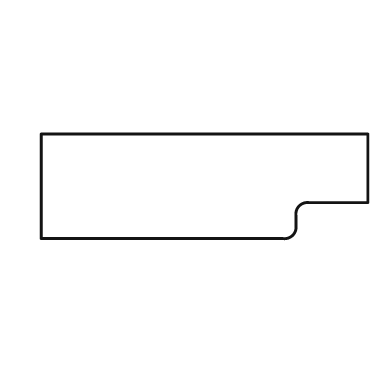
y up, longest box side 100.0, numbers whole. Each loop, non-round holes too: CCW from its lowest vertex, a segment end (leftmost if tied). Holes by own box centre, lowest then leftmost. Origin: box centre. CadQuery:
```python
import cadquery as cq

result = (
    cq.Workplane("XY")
    .moveTo(-50.0, -16.0)
    .lineTo(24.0, -16.0)
    .threePointArc((27.0, -15.0), (28.0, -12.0))
    .lineTo(28.0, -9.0)
    .threePointArc((29.0, -6.0), (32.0, -5.0))
    .lineTo(50.0, -5.0)
    .lineTo(50.0, 16.0)
    .lineTo(-50.0, 16.0)
    .close()
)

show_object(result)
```